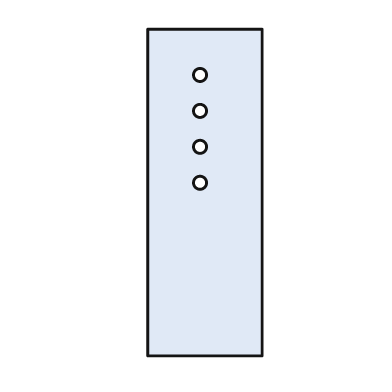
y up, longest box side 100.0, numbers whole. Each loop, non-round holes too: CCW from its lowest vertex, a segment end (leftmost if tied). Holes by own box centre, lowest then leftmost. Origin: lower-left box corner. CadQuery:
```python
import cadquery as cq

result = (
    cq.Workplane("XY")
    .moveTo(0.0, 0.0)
    .lineTo(35.0, 0.0)
    .lineTo(35.0, 100.0)
    .lineTo(0.0, 100.0)
    .close()
    .moveTo(16.0, 53.0)
    .circle(2.0)
    .moveTo(16.0, 64.0)
    .circle(2.0)
    .moveTo(16.0, 75.0)
    .circle(2.0)
    .moveTo(16.0, 86.0)
    .circle(2.0)
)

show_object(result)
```